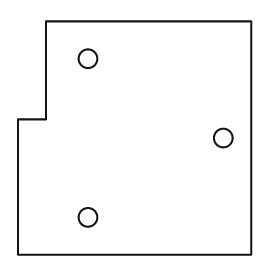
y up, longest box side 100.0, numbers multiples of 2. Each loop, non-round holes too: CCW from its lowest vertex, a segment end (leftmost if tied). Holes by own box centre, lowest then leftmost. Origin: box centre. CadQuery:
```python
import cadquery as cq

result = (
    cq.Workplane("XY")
    .moveTo(-50.0, -50.0)
    .lineTo(50.0, -50.0)
    .lineTo(50.0, 50.0)
    .lineTo(-38.0, 50.0)
    .lineTo(-38.0, 8.0)
    .lineTo(-50.0, 8.0)
    .close()
    .moveTo(-20.0, -34.0)
    .circle(4.0)
    .moveTo(38.0, 0.0)
    .circle(4.0)
    .moveTo(-20.0, 34.0)
    .circle(4.0)
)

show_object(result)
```